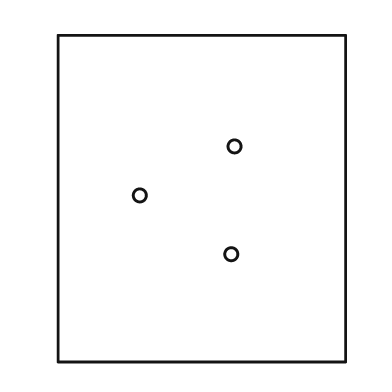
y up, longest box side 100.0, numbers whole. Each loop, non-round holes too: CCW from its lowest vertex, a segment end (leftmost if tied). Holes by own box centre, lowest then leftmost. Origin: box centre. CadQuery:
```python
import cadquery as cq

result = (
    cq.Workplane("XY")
    .moveTo(-44.0, -50.0)
    .lineTo(44.0, -50.0)
    .lineTo(44.0, 50.0)
    .lineTo(-44.0, 50.0)
    .close()
    .moveTo(9.0, -17.0)
    .circle(2.0)
    .moveTo(-19.0, 1.0)
    .circle(2.0)
    .moveTo(10.0, 16.0)
    .circle(2.0)
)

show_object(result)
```